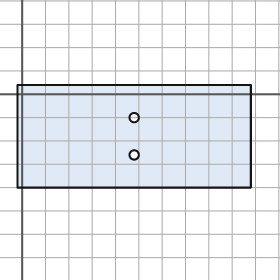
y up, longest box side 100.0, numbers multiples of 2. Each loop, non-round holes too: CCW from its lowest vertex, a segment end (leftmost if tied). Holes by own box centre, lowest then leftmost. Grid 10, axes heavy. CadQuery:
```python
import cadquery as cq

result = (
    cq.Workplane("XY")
    .moveTo(-2.0, -40.0)
    .lineTo(98.0, -40.0)
    .lineTo(98.0, 4.0)
    .lineTo(-2.0, 4.0)
    .close()
    .moveTo(48.0, -26.0)
    .circle(2.0)
    .moveTo(48.0, -10.0)
    .circle(2.0)
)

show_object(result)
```